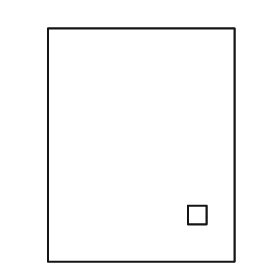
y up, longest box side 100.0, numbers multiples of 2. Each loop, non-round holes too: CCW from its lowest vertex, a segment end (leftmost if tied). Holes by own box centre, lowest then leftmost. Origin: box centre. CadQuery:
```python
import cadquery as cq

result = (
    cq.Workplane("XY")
    .moveTo(-40.0, -50.0)
    .lineTo(40.0, -50.0)
    .lineTo(40.0, 50.0)
    .lineTo(-40.0, 50.0)
    .close()
    .moveTo(20.0, -34.0)
    .lineTo(28.0, -34.0)
    .lineTo(28.0, -26.0)
    .lineTo(20.0, -26.0)
    .close()
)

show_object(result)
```